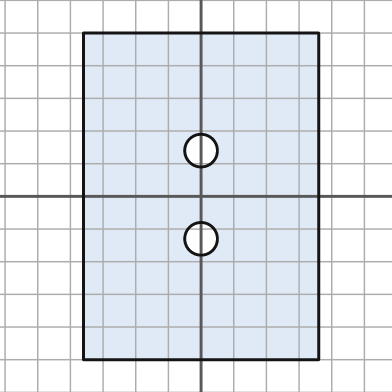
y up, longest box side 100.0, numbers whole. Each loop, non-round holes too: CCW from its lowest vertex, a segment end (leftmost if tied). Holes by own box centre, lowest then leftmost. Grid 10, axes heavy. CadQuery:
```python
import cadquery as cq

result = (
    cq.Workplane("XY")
    .moveTo(-36.0, -50.0)
    .lineTo(36.0, -50.0)
    .lineTo(36.0, 50.0)
    .lineTo(-36.0, 50.0)
    .close()
    .moveTo(0.0, -13.0)
    .circle(5.0)
    .moveTo(0.0, 14.0)
    .circle(5.0)
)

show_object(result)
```